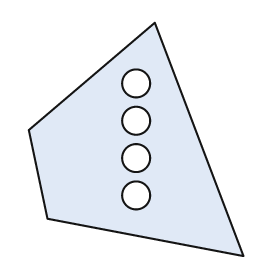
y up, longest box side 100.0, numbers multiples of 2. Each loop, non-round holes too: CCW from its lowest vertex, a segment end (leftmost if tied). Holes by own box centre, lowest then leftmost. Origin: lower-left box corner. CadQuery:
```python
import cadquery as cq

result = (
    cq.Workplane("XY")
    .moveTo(92.0, 0.0)
    .lineTo(54.0, 100.0)
    .lineTo(0.0, 54.0)
    .lineTo(8.0, 16.0)
    .close()
    .moveTo(46.0, 26.0)
    .circle(6.0)
    .moveTo(46.0, 42.0)
    .circle(6.0)
    .moveTo(46.0, 58.0)
    .circle(6.0)
    .moveTo(46.0, 74.0)
    .circle(6.0)
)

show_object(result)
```